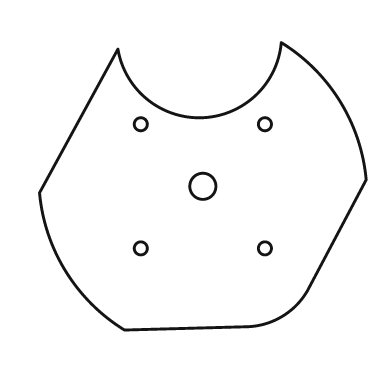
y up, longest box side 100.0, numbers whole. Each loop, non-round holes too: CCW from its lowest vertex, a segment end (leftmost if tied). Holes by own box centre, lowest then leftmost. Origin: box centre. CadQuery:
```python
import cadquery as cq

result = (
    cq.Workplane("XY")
    .moveTo(-24.0, -44.0)
    .lineTo(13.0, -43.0)
    .threePointArc((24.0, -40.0), (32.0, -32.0))
    .lineTo(50.0, 2.0)
    .threePointArc((42.0, 26.0), (24.0, 44.0))
    .threePointArc((0.0, 21.0), (-26.0, 42.0))
    .lineTo(-50.0, -2.0)
    .threePointArc((-42.0, -26.0), (-24.0, -44.0))
    .close()
    .moveTo(-19.0, -19.0)
    .circle(2.0)
    .moveTo(19.0, -19.0)
    .circle(2.0)
    .moveTo(0.0, 0.0)
    .circle(4.0)
    .moveTo(-19.0, 19.0)
    .circle(2.0)
    .moveTo(19.0, 19.0)
    .circle(2.0)
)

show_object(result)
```